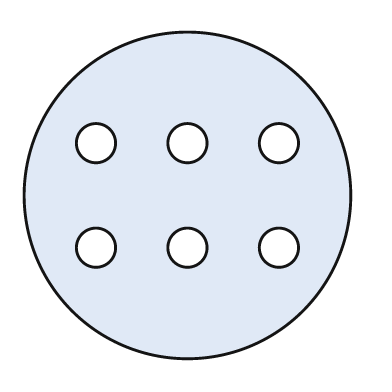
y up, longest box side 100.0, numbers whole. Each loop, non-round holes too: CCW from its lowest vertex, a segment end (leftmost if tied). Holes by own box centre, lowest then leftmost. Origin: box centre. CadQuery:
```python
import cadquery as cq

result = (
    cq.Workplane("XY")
    .moveTo(0.0, 0.0)
    .circle(50.0)
    .moveTo(-28.0, -16.0)
    .circle(6.0)
    .moveTo(0.0, -16.0)
    .circle(6.0)
    .moveTo(28.0, -16.0)
    .circle(6.0)
    .moveTo(-28.0, 16.0)
    .circle(6.0)
    .moveTo(0.0, 16.0)
    .circle(6.0)
    .moveTo(28.0, 16.0)
    .circle(6.0)
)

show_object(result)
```